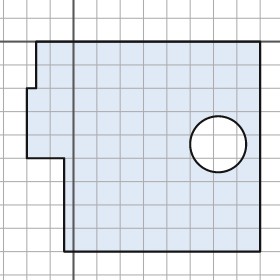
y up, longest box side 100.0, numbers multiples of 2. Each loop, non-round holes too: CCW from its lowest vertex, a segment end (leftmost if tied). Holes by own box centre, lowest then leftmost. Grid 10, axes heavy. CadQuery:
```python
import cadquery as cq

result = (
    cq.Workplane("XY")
    .moveTo(-4.0, -90.0)
    .lineTo(80.0, -90.0)
    .lineTo(80.0, 0.0)
    .lineTo(-16.0, 0.0)
    .lineTo(-16.0, -20.0)
    .lineTo(-20.0, -20.0)
    .lineTo(-20.0, -50.0)
    .lineTo(-4.0, -50.0)
    .close()
    .moveTo(62.0, -44.0)
    .circle(12.0)
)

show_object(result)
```